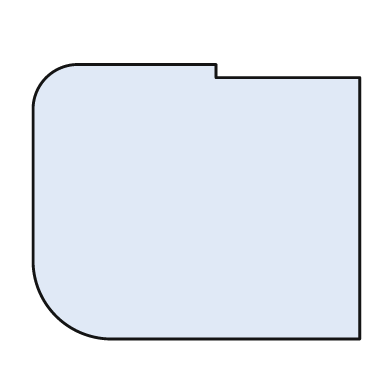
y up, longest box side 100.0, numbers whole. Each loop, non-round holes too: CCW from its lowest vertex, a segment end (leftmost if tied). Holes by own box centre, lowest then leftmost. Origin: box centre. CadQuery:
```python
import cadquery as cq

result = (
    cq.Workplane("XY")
    .moveTo(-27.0, -42.0)
    .lineTo(50.0, -42.0)
    .lineTo(50.0, 38.0)
    .lineTo(6.0, 38.0)
    .lineTo(6.0, 42.0)
    .lineTo(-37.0, 42.0)
    .threePointArc((-46.0, 38.0), (-50.0, 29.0))
    .lineTo(-50.0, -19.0)
    .threePointArc((-43.0, -35.0), (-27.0, -42.0))
    .close()
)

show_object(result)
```